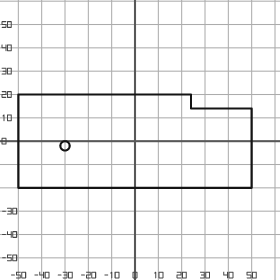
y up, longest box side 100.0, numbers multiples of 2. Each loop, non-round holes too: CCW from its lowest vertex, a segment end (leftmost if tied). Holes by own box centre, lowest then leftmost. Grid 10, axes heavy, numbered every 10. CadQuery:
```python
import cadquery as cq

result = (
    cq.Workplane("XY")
    .moveTo(-50.0, -20.0)
    .lineTo(50.0, -20.0)
    .lineTo(50.0, 14.0)
    .lineTo(24.0, 14.0)
    .lineTo(24.0, 20.0)
    .lineTo(-50.0, 20.0)
    .close()
    .moveTo(-30.0, -2.0)
    .circle(2.0)
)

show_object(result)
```